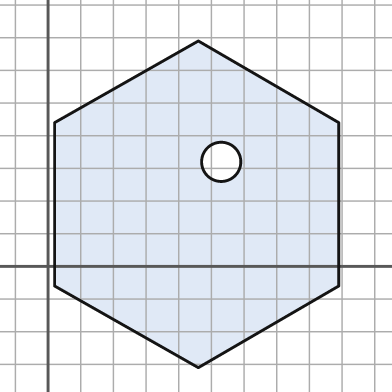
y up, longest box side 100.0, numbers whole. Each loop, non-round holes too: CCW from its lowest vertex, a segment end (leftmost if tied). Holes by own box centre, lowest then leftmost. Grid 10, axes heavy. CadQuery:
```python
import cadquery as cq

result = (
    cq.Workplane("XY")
    .moveTo(46.0, -31.0)
    .lineTo(89.0, -6.0)
    .lineTo(89.0, 44.0)
    .lineTo(46.0, 69.0)
    .lineTo(2.0, 44.0)
    .lineTo(2.0, -6.0)
    .close()
    .moveTo(53.0, 32.0)
    .circle(6.0)
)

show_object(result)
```